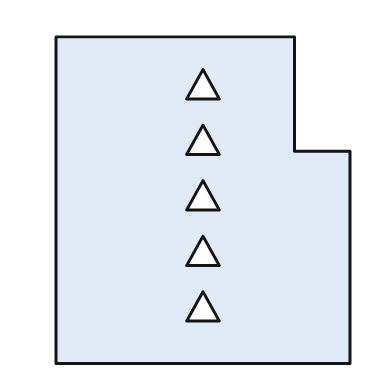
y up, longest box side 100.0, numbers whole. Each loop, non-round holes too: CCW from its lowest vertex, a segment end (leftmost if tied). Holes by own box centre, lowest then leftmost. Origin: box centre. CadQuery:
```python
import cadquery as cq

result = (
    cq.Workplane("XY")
    .moveTo(-45.0, -50.0)
    .lineTo(45.0, -50.0)
    .lineTo(45.0, 15.0)
    .lineTo(28.0, 15.0)
    .lineTo(28.0, 50.0)
    .lineTo(-45.0, 50.0)
    .close()
    .moveTo(-5.0, -37.0)
    .lineTo(5.0, -37.0)
    .lineTo(0.0, -28.0)
    .close()
    .moveTo(-5.0, -20.0)
    .lineTo(5.0, -20.0)
    .lineTo(0.0, -11.0)
    .close()
    .moveTo(-5.0, -3.0)
    .lineTo(5.0, -3.0)
    .lineTo(0.0, 6.0)
    .close()
    .moveTo(-5.0, 14.0)
    .lineTo(5.0, 14.0)
    .lineTo(0.0, 23.0)
    .close()
    .moveTo(-5.0, 31.0)
    .lineTo(5.0, 31.0)
    .lineTo(0.0, 40.0)
    .close()
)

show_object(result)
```